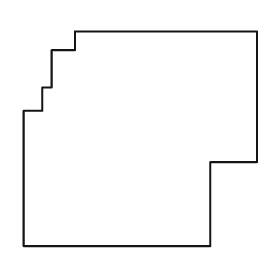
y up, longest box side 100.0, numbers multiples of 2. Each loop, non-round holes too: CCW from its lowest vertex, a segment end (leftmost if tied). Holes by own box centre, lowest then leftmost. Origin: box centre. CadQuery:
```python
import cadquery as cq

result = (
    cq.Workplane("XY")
    .moveTo(-50.0, -46.0)
    .lineTo(30.0, -46.0)
    .lineTo(30.0, -10.0)
    .lineTo(50.0, -10.0)
    .lineTo(50.0, 46.0)
    .lineTo(-28.0, 46.0)
    .lineTo(-28.0, 38.0)
    .lineTo(-38.0, 38.0)
    .lineTo(-38.0, 22.0)
    .lineTo(-42.0, 22.0)
    .lineTo(-42.0, 12.0)
    .lineTo(-50.0, 12.0)
    .close()
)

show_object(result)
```